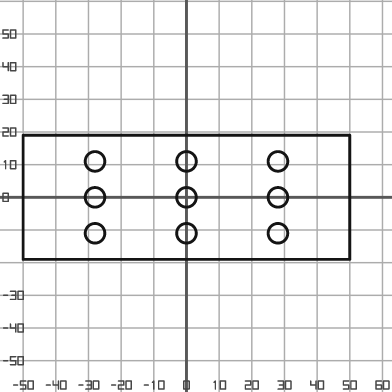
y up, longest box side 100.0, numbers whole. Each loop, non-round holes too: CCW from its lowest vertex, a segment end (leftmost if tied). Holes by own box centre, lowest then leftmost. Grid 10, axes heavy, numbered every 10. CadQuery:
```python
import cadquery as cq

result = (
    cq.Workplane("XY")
    .moveTo(-50.0, -19.0)
    .lineTo(50.0, -19.0)
    .lineTo(50.0, 19.0)
    .lineTo(-50.0, 19.0)
    .close()
    .moveTo(-28.0, -11.0)
    .circle(3.0)
    .moveTo(0.0, -11.0)
    .circle(3.0)
    .moveTo(28.0, -11.0)
    .circle(3.0)
    .moveTo(-28.0, 0.0)
    .circle(3.0)
    .moveTo(0.0, 0.0)
    .circle(3.0)
    .moveTo(28.0, 0.0)
    .circle(3.0)
    .moveTo(-28.0, 11.0)
    .circle(3.0)
    .moveTo(0.0, 11.0)
    .circle(3.0)
    .moveTo(28.0, 11.0)
    .circle(3.0)
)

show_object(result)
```